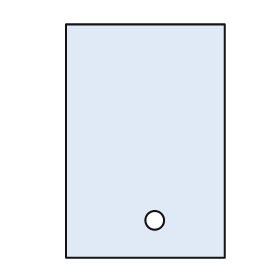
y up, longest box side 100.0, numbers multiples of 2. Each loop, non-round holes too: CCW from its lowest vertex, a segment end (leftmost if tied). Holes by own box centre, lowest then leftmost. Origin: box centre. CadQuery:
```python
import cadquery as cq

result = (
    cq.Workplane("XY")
    .moveTo(-34.0, -50.0)
    .lineTo(34.0, -50.0)
    .lineTo(34.0, 50.0)
    .lineTo(-34.0, 50.0)
    .close()
    .moveTo(4.0, -34.0)
    .circle(4.0)
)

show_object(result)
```